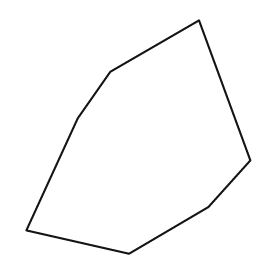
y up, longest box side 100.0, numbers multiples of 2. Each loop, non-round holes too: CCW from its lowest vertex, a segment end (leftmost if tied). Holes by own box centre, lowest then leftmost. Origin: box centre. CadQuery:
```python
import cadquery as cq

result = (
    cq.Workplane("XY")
    .moveTo(-4.0, -50.0)
    .lineTo(30.0, -30.0)
    .lineTo(48.0, -10.0)
    .lineTo(26.0, 50.0)
    .lineTo(-12.0, 28.0)
    .lineTo(-26.0, 8.0)
    .lineTo(-48.0, -40.0)
    .close()
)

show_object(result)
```